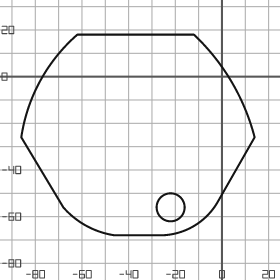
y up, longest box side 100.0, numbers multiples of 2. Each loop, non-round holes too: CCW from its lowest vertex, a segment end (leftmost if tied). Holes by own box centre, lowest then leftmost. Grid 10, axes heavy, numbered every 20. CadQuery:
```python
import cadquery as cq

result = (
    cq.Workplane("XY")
    .moveTo(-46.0, -68.0)
    .lineTo(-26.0, -68.0)
    .threePointArc((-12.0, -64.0), (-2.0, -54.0))
    .lineTo(14.0, -26.0)
    .threePointArc((4.0, -2.0), (-12.0, 18.0))
    .lineTo(-62.0, 18.0)
    .threePointArc((-78.0, -2.0), (-86.0, -26.0))
    .lineTo(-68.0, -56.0)
    .threePointArc((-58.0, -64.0), (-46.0, -68.0))
    .close()
    .moveTo(-22.0, -56.0)
    .circle(6.0)
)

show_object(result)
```